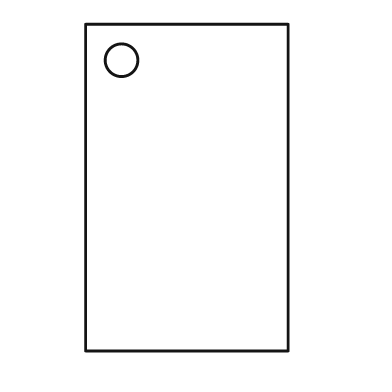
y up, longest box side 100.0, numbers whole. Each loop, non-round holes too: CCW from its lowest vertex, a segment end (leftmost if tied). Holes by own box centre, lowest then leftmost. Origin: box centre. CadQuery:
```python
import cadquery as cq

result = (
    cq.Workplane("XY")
    .moveTo(-31.0, -50.0)
    .lineTo(31.0, -50.0)
    .lineTo(31.0, 50.0)
    .lineTo(-31.0, 50.0)
    .close()
    .moveTo(-20.0, 39.0)
    .circle(5.0)
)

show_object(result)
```